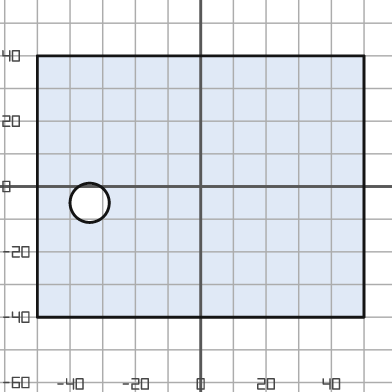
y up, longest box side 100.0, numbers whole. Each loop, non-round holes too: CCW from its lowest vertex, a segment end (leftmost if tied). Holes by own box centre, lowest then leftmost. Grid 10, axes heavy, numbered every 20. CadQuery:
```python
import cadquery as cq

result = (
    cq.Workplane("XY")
    .moveTo(-50.0, -40.0)
    .lineTo(50.0, -40.0)
    .lineTo(50.0, 40.0)
    .lineTo(-50.0, 40.0)
    .close()
    .moveTo(-34.0, -5.0)
    .circle(6.0)
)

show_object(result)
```